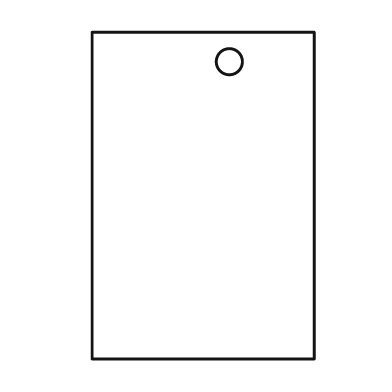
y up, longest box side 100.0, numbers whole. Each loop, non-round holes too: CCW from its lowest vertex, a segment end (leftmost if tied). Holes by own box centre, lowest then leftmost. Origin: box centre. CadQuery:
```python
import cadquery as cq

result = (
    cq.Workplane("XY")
    .moveTo(-34.0, -50.0)
    .lineTo(34.0, -50.0)
    .lineTo(34.0, 50.0)
    .lineTo(-34.0, 50.0)
    .close()
    .moveTo(8.0, 41.0)
    .circle(4.0)
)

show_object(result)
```